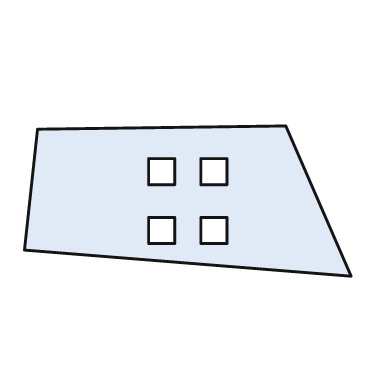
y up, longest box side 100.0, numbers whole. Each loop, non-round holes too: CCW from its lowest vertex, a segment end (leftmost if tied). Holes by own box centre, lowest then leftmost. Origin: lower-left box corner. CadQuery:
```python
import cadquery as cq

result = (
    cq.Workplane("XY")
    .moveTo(100.0, 0.0)
    .lineTo(80.0, 46.0)
    .lineTo(4.0, 45.0)
    .lineTo(0.0, 8.0)
    .close()
    .moveTo(38.0, 10.0)
    .lineTo(46.0, 10.0)
    .lineTo(46.0, 18.0)
    .lineTo(38.0, 18.0)
    .close()
    .moveTo(54.0, 10.0)
    .lineTo(62.0, 10.0)
    .lineTo(62.0, 18.0)
    .lineTo(54.0, 18.0)
    .close()
    .moveTo(38.0, 28.0)
    .lineTo(46.0, 28.0)
    .lineTo(46.0, 36.0)
    .lineTo(38.0, 36.0)
    .close()
    .moveTo(54.0, 28.0)
    .lineTo(62.0, 28.0)
    .lineTo(62.0, 36.0)
    .lineTo(54.0, 36.0)
    .close()
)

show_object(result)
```